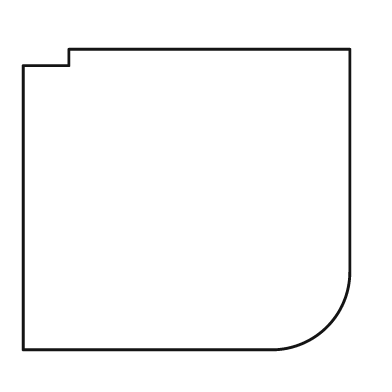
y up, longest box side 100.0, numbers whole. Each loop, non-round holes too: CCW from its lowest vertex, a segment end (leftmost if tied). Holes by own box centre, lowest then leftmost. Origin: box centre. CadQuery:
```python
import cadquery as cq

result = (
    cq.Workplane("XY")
    .moveTo(-50.0, -46.0)
    .lineTo(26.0, -46.0)
    .threePointArc((43.0, -39.0), (50.0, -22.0))
    .lineTo(50.0, 46.0)
    .lineTo(-36.0, 46.0)
    .lineTo(-36.0, 41.0)
    .lineTo(-50.0, 41.0)
    .close()
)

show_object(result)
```